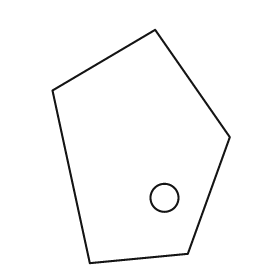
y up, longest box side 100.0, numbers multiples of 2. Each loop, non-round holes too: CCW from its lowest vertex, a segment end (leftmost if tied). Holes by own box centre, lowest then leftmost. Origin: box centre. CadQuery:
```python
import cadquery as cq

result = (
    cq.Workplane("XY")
    .moveTo(-22.0, -50.0)
    .lineTo(20.0, -46.0)
    .lineTo(38.0, 4.0)
    .lineTo(6.0, 50.0)
    .lineTo(-38.0, 24.0)
    .close()
    .moveTo(10.0, -22.0)
    .circle(6.0)
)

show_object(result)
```